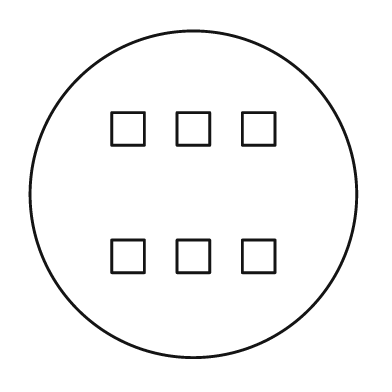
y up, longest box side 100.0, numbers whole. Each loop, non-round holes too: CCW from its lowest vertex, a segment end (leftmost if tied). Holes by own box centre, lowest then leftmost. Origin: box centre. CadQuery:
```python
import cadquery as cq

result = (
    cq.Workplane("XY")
    .moveTo(0.0, 0.0)
    .circle(50.0)
    .moveTo(-25.0, -24.0)
    .lineTo(-15.0, -24.0)
    .lineTo(-15.0, -14.0)
    .lineTo(-25.0, -14.0)
    .close()
    .moveTo(-5.0, -24.0)
    .lineTo(5.0, -24.0)
    .lineTo(5.0, -14.0)
    .lineTo(-5.0, -14.0)
    .close()
    .moveTo(15.0, -24.0)
    .lineTo(25.0, -24.0)
    .lineTo(25.0, -14.0)
    .lineTo(15.0, -14.0)
    .close()
    .moveTo(-25.0, 15.0)
    .lineTo(-15.0, 15.0)
    .lineTo(-15.0, 25.0)
    .lineTo(-25.0, 25.0)
    .close()
    .moveTo(-5.0, 15.0)
    .lineTo(5.0, 15.0)
    .lineTo(5.0, 25.0)
    .lineTo(-5.0, 25.0)
    .close()
    .moveTo(15.0, 15.0)
    .lineTo(25.0, 15.0)
    .lineTo(25.0, 25.0)
    .lineTo(15.0, 25.0)
    .close()
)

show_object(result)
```